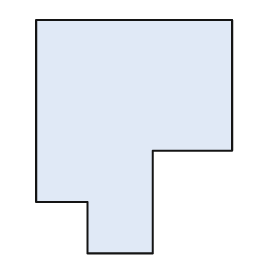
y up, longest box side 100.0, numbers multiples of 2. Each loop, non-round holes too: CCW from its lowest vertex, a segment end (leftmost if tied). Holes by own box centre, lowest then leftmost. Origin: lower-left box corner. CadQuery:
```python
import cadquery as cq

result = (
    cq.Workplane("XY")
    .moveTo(22.0, 0.0)
    .lineTo(50.0, 0.0)
    .lineTo(50.0, 44.0)
    .lineTo(84.0, 44.0)
    .lineTo(84.0, 100.0)
    .lineTo(0.0, 100.0)
    .lineTo(0.0, 22.0)
    .lineTo(22.0, 22.0)
    .close()
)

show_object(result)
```